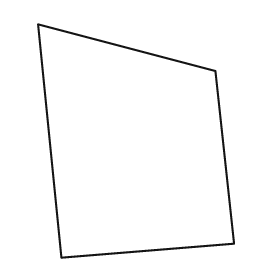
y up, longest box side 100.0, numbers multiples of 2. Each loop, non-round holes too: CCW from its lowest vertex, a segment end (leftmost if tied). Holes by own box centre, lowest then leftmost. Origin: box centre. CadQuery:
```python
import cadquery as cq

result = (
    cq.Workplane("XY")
    .moveTo(-32.0, -50.0)
    .lineTo(42.0, -44.0)
    .lineTo(34.0, 30.0)
    .lineTo(-42.0, 50.0)
    .close()
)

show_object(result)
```